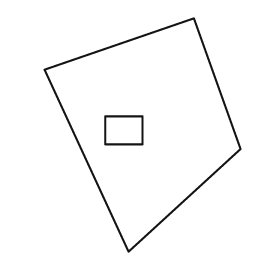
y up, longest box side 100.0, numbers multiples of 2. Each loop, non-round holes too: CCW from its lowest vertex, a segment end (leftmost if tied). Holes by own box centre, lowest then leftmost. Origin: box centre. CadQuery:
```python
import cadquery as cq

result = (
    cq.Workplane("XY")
    .moveTo(-6.0, -50.0)
    .lineTo(42.0, -6.0)
    .lineTo(22.0, 50.0)
    .lineTo(-42.0, 28.0)
    .close()
    .moveTo(-16.0, -4.0)
    .lineTo(0.0, -4.0)
    .lineTo(0.0, 8.0)
    .lineTo(-16.0, 8.0)
    .close()
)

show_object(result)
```